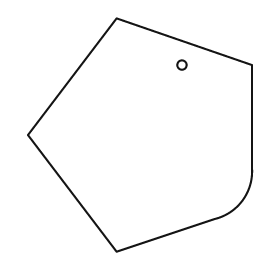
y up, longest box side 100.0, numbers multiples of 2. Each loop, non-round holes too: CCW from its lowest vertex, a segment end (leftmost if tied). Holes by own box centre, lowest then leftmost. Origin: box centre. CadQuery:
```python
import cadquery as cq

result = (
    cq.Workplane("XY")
    .moveTo(-10.0, -50.0)
    .lineTo(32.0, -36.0)
    .threePointArc((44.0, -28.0), (48.0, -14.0))
    .lineTo(48.0, 30.0)
    .lineTo(-10.0, 50.0)
    .lineTo(-48.0, 0.0)
    .close()
    .moveTo(18.0, 30.0)
    .circle(2.0)
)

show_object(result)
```